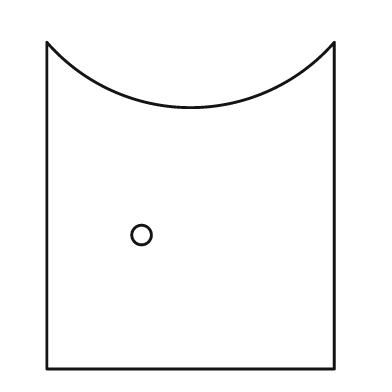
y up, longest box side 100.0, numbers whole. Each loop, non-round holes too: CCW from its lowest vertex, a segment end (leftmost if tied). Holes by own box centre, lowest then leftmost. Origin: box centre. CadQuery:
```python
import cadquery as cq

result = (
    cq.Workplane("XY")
    .moveTo(-44.0, -50.0)
    .lineTo(44.0, -50.0)
    .lineTo(44.0, 50.0)
    .threePointArc((0.0, 30.0), (-44.0, 50.0))
    .close()
    .moveTo(-15.0, -9.0)
    .circle(3.0)
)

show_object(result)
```